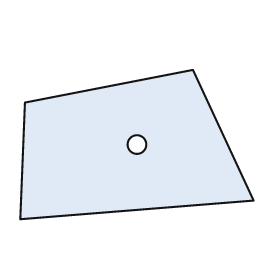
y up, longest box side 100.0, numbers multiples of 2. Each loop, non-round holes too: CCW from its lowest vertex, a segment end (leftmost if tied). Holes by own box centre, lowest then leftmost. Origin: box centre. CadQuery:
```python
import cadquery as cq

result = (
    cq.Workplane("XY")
    .moveTo(-50.0, -32.0)
    .lineTo(50.0, -24.0)
    .lineTo(24.0, 32.0)
    .lineTo(-48.0, 18.0)
    .close()
    .moveTo(0.0, 0.0)
    .circle(4.0)
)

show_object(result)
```